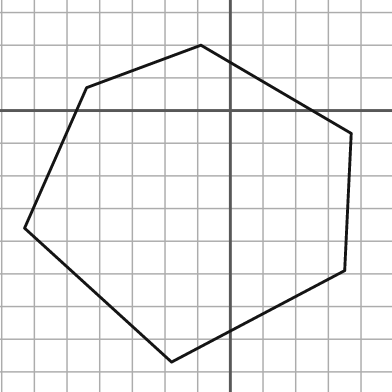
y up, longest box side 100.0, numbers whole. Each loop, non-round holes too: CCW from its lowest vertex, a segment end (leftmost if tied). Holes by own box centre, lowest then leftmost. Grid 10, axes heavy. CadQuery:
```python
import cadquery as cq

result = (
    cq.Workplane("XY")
    .moveTo(-18.0, -77.0)
    .lineTo(35.0, -49.0)
    .lineTo(37.0, -7.0)
    .lineTo(-9.0, 20.0)
    .lineTo(-44.0, 7.0)
    .lineTo(-63.0, -36.0)
    .close()
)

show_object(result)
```